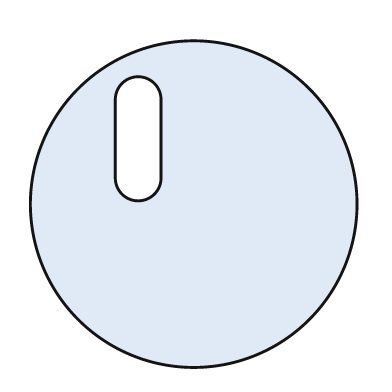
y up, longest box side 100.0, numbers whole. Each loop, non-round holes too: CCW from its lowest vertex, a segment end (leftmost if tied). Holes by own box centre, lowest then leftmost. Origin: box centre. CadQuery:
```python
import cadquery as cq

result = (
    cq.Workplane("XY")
    .moveTo(0.0, 0.0)
    .circle(50.0)
    .moveTo(-24.0, 8.0)
    .threePointArc((-17.0, 1.0), (-10.0, 8.0))
    .lineTo(-10.0, 32.0)
    .threePointArc((-17.0, 39.0), (-24.0, 32.0))
    .close()
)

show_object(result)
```